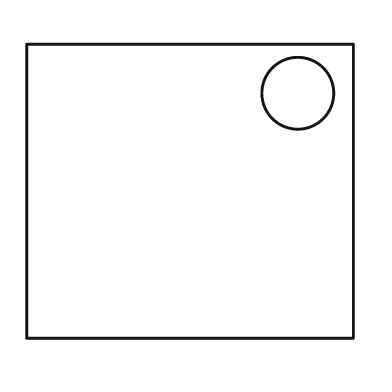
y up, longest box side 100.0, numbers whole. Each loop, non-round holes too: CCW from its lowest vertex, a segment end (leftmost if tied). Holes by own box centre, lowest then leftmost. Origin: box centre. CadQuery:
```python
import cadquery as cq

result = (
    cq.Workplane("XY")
    .moveTo(-50.0, -45.0)
    .lineTo(50.0, -45.0)
    .lineTo(50.0, 45.0)
    .lineTo(-50.0, 45.0)
    .close()
    .moveTo(33.0, 30.0)
    .circle(11.0)
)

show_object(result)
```